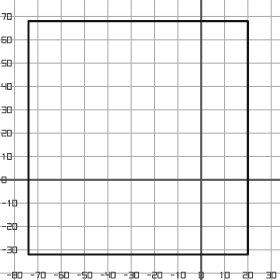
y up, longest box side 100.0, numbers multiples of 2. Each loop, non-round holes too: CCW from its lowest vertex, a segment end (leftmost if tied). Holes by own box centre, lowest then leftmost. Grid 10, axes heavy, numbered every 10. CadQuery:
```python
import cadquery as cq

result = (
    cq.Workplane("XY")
    .moveTo(-74.0, -32.0)
    .lineTo(20.0, -32.0)
    .lineTo(20.0, 68.0)
    .lineTo(-74.0, 68.0)
    .close()
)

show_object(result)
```